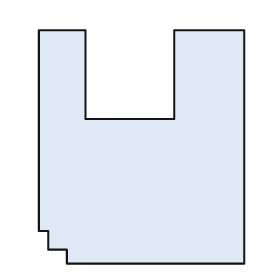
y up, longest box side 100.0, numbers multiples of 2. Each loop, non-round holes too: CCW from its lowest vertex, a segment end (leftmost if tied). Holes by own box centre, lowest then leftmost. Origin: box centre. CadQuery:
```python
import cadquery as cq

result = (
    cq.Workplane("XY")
    .moveTo(-32.0, -50.0)
    .lineTo(44.0, -50.0)
    .lineTo(44.0, 50.0)
    .lineTo(14.0, 50.0)
    .lineTo(14.0, 12.0)
    .lineTo(-24.0, 12.0)
    .lineTo(-24.0, 50.0)
    .lineTo(-44.0, 50.0)
    .lineTo(-44.0, -36.0)
    .lineTo(-40.0, -36.0)
    .lineTo(-40.0, -44.0)
    .lineTo(-32.0, -44.0)
    .close()
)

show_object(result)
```